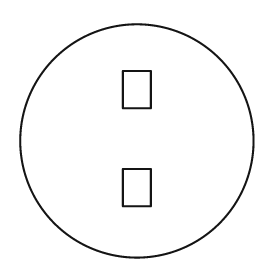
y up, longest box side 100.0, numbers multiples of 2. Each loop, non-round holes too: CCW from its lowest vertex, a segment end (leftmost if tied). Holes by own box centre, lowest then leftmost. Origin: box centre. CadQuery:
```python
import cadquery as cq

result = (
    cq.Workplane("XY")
    .moveTo(0.0, 0.0)
    .circle(50.0)
    .moveTo(-6.0, -28.0)
    .lineTo(6.0, -28.0)
    .lineTo(6.0, -12.0)
    .lineTo(-6.0, -12.0)
    .close()
    .moveTo(-6.0, 14.0)
    .lineTo(6.0, 14.0)
    .lineTo(6.0, 30.0)
    .lineTo(-6.0, 30.0)
    .close()
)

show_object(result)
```